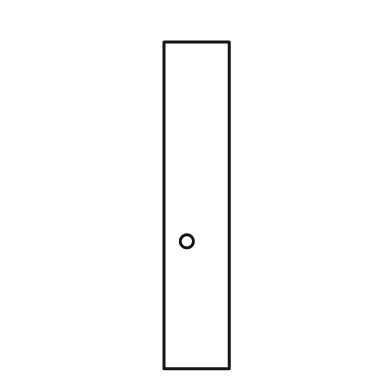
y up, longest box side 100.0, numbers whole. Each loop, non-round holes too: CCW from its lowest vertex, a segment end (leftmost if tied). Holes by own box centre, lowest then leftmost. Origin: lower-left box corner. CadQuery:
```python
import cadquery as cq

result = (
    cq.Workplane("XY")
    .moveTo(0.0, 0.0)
    .lineTo(20.0, 0.0)
    .lineTo(20.0, 100.0)
    .lineTo(0.0, 100.0)
    .close()
    .moveTo(7.0, 39.0)
    .circle(2.0)
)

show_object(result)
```